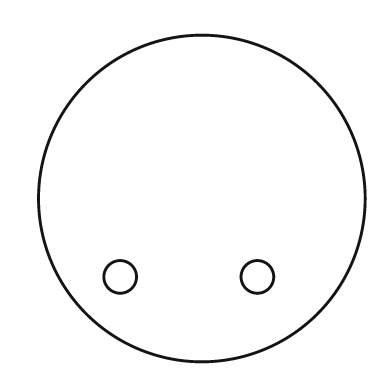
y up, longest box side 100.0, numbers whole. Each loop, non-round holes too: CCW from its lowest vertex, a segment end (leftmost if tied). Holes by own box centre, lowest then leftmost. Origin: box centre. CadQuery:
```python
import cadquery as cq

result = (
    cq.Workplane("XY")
    .moveTo(0.0, 0.0)
    .circle(50.0)
    .moveTo(-25.0, -24.0)
    .circle(5.0)
    .moveTo(17.0, -24.0)
    .circle(5.0)
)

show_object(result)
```